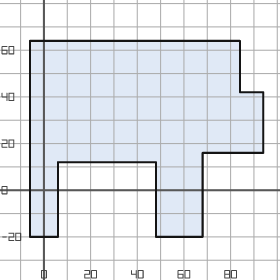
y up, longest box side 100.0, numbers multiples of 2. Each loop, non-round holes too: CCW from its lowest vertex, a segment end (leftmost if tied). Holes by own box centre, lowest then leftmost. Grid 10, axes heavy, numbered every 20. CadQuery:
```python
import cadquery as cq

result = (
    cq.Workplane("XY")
    .moveTo(-6.0, -20.0)
    .lineTo(6.0, -20.0)
    .lineTo(6.0, 12.0)
    .lineTo(48.0, 12.0)
    .lineTo(48.0, -20.0)
    .lineTo(68.0, -20.0)
    .lineTo(68.0, 16.0)
    .lineTo(94.0, 16.0)
    .lineTo(94.0, 42.0)
    .lineTo(84.0, 42.0)
    .lineTo(84.0, 64.0)
    .lineTo(-6.0, 64.0)
    .close()
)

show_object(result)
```